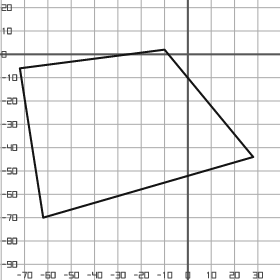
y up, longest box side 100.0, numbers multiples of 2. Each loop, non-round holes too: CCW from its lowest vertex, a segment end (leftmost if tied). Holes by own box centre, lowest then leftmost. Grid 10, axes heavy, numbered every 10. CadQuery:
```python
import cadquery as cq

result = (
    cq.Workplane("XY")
    .moveTo(-62.0, -70.0)
    .lineTo(28.0, -44.0)
    .lineTo(-10.0, 2.0)
    .lineTo(-72.0, -6.0)
    .close()
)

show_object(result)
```